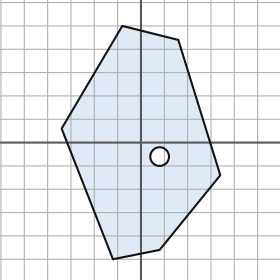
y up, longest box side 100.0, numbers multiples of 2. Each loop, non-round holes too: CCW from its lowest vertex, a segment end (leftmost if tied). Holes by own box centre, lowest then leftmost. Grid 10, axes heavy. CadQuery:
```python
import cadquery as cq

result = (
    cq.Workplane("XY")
    .moveTo(-12.0, -50.0)
    .lineTo(8.0, -46.0)
    .lineTo(34.0, -14.0)
    .lineTo(16.0, 44.0)
    .lineTo(-8.0, 50.0)
    .lineTo(-34.0, 6.0)
    .close()
    .moveTo(8.0, -6.0)
    .circle(4.0)
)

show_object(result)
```